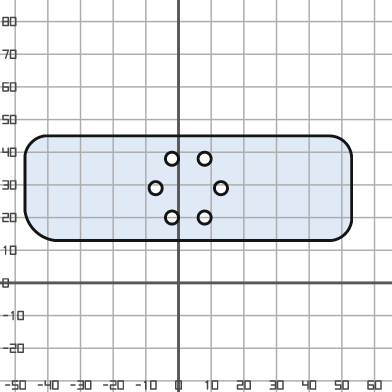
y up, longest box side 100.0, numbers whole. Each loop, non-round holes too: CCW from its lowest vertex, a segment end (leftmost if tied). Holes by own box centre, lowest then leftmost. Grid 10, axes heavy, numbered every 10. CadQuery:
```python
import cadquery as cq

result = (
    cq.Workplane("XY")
    .moveTo(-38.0, 13.0)
    .lineTo(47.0, 13.0)
    .threePointArc((51.0, 15.0), (53.0, 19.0))
    .lineTo(53.0, 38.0)
    .threePointArc((51.0, 43.0), (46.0, 45.0))
    .lineTo(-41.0, 45.0)
    .threePointArc((-45.0, 43.0), (-47.0, 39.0))
    .lineTo(-47.0, 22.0)
    .threePointArc((-44.0, 16.0), (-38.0, 13.0))
    .close()
    .moveTo(-2.0, 20.0)
    .circle(2.0)
    .moveTo(8.0, 20.0)
    .circle(2.0)
    .moveTo(-7.0, 29.0)
    .circle(2.0)
    .moveTo(13.0, 29.0)
    .circle(2.0)
    .moveTo(-2.0, 38.0)
    .circle(2.0)
    .moveTo(8.0, 38.0)
    .circle(2.0)
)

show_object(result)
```